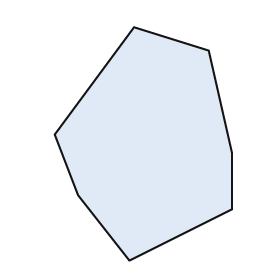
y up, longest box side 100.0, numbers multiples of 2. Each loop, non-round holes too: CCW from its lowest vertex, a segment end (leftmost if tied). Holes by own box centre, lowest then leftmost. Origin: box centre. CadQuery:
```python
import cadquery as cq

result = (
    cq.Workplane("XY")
    .moveTo(-6.0, -50.0)
    .lineTo(38.0, -28.0)
    .lineTo(38.0, -4.0)
    .lineTo(28.0, 40.0)
    .lineTo(-4.0, 50.0)
    .lineTo(-38.0, 4.0)
    .lineTo(-28.0, -22.0)
    .close()
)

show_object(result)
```